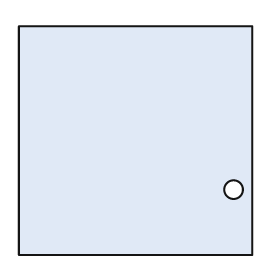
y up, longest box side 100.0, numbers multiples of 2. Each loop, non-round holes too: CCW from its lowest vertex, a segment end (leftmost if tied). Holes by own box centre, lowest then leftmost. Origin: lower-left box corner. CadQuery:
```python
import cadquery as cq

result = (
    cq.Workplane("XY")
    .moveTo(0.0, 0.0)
    .lineTo(100.0, 0.0)
    .lineTo(100.0, 98.0)
    .lineTo(0.0, 98.0)
    .close()
    .moveTo(92.0, 28.0)
    .circle(4.0)
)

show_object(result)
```